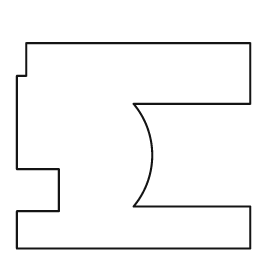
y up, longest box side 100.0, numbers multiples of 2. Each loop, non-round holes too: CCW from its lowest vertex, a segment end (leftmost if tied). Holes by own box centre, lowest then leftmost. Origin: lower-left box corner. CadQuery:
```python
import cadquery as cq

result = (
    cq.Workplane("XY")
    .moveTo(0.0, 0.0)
    .lineTo(100.0, 0.0)
    .lineTo(100.0, 18.0)
    .lineTo(50.0, 18.0)
    .threePointArc((58.0, 40.0), (50.0, 62.0))
    .lineTo(100.0, 62.0)
    .lineTo(100.0, 88.0)
    .lineTo(4.0, 88.0)
    .lineTo(4.0, 74.0)
    .lineTo(0.0, 74.0)
    .lineTo(0.0, 34.0)
    .lineTo(18.0, 34.0)
    .lineTo(18.0, 16.0)
    .lineTo(0.0, 16.0)
    .close()
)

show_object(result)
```